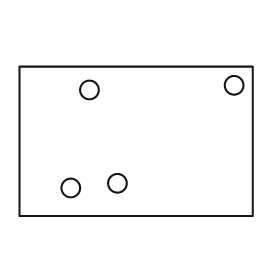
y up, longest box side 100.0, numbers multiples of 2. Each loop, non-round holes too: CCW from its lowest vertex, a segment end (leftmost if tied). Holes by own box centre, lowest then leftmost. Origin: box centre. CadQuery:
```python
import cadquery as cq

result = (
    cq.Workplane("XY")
    .moveTo(-50.0, -32.0)
    .lineTo(50.0, -32.0)
    .lineTo(50.0, 32.0)
    .lineTo(-50.0, 32.0)
    .close()
    .moveTo(-28.0, -20.0)
    .circle(4.0)
    .moveTo(-8.0, -18.0)
    .circle(4.0)
    .moveTo(-20.0, 22.0)
    .circle(4.0)
    .moveTo(42.0, 24.0)
    .circle(4.0)
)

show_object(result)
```